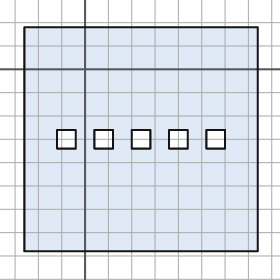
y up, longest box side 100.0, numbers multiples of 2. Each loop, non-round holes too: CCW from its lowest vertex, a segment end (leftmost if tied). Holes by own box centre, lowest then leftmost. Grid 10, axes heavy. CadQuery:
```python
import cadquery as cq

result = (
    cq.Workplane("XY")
    .moveTo(-26.0, -78.0)
    .lineTo(74.0, -78.0)
    .lineTo(74.0, 18.0)
    .lineTo(-26.0, 18.0)
    .close()
    .moveTo(-12.0, -34.0)
    .lineTo(-4.0, -34.0)
    .lineTo(-4.0, -26.0)
    .lineTo(-12.0, -26.0)
    .close()
    .moveTo(4.0, -34.0)
    .lineTo(12.0, -34.0)
    .lineTo(12.0, -26.0)
    .lineTo(4.0, -26.0)
    .close()
    .moveTo(20.0, -34.0)
    .lineTo(28.0, -34.0)
    .lineTo(28.0, -26.0)
    .lineTo(20.0, -26.0)
    .close()
    .moveTo(36.0, -34.0)
    .lineTo(44.0, -34.0)
    .lineTo(44.0, -26.0)
    .lineTo(36.0, -26.0)
    .close()
    .moveTo(52.0, -34.0)
    .lineTo(60.0, -34.0)
    .lineTo(60.0, -26.0)
    .lineTo(52.0, -26.0)
    .close()
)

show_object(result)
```